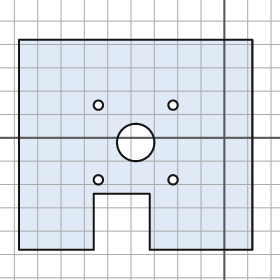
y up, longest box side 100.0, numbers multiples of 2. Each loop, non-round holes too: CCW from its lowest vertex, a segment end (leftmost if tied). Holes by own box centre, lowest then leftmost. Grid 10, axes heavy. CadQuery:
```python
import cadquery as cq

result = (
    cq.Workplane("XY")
    .moveTo(-88.0, -48.0)
    .lineTo(-56.0, -48.0)
    .lineTo(-56.0, -24.0)
    .lineTo(-32.0, -24.0)
    .lineTo(-32.0, -48.0)
    .lineTo(12.0, -48.0)
    .lineTo(12.0, 42.0)
    .lineTo(-88.0, 42.0)
    .close()
    .moveTo(-54.0, -18.0)
    .circle(2.0)
    .moveTo(-22.0, -18.0)
    .circle(2.0)
    .moveTo(-38.0, -2.0)
    .circle(8.0)
    .moveTo(-54.0, 14.0)
    .circle(2.0)
    .moveTo(-22.0, 14.0)
    .circle(2.0)
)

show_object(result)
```